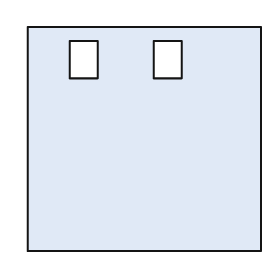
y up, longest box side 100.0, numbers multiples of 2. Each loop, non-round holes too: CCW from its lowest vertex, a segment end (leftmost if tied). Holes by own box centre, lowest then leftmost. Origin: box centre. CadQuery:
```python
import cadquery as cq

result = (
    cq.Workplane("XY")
    .moveTo(-50.0, -48.0)
    .lineTo(50.0, -48.0)
    .lineTo(50.0, 48.0)
    .lineTo(-50.0, 48.0)
    .close()
    .moveTo(-32.0, 26.0)
    .lineTo(-20.0, 26.0)
    .lineTo(-20.0, 42.0)
    .lineTo(-32.0, 42.0)
    .close()
    .moveTo(4.0, 26.0)
    .lineTo(16.0, 26.0)
    .lineTo(16.0, 42.0)
    .lineTo(4.0, 42.0)
    .close()
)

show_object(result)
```